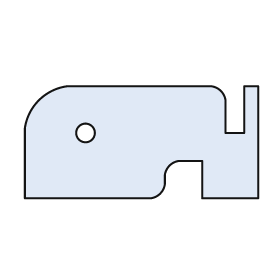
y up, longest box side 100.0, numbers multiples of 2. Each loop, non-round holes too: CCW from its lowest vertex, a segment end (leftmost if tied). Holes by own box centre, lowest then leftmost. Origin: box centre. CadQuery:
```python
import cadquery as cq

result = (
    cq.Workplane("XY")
    .moveTo(-50.0, -24.0)
    .lineTo(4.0, -24.0)
    .threePointArc((8.0, -22.0), (10.0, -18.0))
    .lineTo(10.0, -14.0)
    .threePointArc((12.0, -10.0), (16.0, -8.0))
    .lineTo(26.0, -8.0)
    .lineTo(26.0, -24.0)
    .lineTo(50.0, -24.0)
    .lineTo(50.0, 24.0)
    .lineTo(44.0, 24.0)
    .lineTo(44.0, 4.0)
    .lineTo(36.0, 4.0)
    .lineTo(36.0, 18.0)
    .threePointArc((34.0, 22.0), (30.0, 24.0))
    .lineTo(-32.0, 24.0)
    .threePointArc((-44.0, 18.0), (-50.0, 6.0))
    .close()
    .moveTo(-24.0, 4.0)
    .circle(4.0)
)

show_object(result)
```